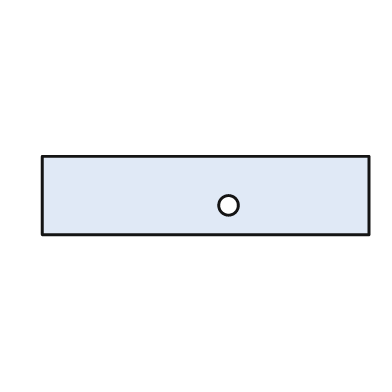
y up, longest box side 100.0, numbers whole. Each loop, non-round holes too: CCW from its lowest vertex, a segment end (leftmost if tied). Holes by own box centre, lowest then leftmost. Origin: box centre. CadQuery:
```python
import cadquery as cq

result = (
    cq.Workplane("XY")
    .moveTo(-50.0, -12.0)
    .lineTo(50.0, -12.0)
    .lineTo(50.0, 12.0)
    .lineTo(-50.0, 12.0)
    .close()
    .moveTo(7.0, -3.0)
    .circle(3.0)
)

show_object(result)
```